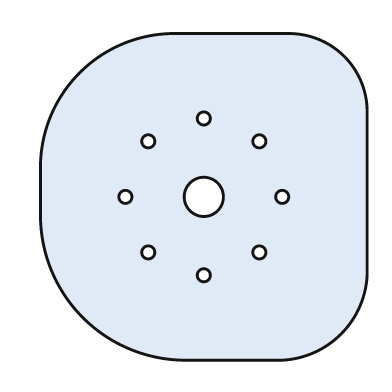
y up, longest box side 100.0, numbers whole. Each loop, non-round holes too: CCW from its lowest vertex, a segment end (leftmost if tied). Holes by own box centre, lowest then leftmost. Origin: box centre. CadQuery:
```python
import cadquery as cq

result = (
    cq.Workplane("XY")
    .moveTo(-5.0, -50.0)
    .lineTo(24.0, -50.0)
    .threePointArc((42.0, -42.0), (50.0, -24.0))
    .lineTo(50.0, 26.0)
    .threePointArc((43.0, 43.0), (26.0, 50.0))
    .lineTo(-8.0, 50.0)
    .threePointArc((-38.0, 38.0), (-50.0, 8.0))
    .lineTo(-50.0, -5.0)
    .threePointArc((-37.0, -37.0), (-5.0, -50.0))
    .close()
    .moveTo(0.0, -24.0)
    .circle(2.0)
    .moveTo(-17.0, -17.0)
    .circle(2.0)
    .moveTo(17.0, -17.0)
    .circle(2.0)
    .moveTo(-24.0, 0.0)
    .circle(2.0)
    .moveTo(0.0, 0.0)
    .circle(6.0)
    .moveTo(24.0, 0.0)
    .circle(2.0)
    .moveTo(-17.0, 17.0)
    .circle(2.0)
    .moveTo(17.0, 17.0)
    .circle(2.0)
    .moveTo(0.0, 24.0)
    .circle(2.0)
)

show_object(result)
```